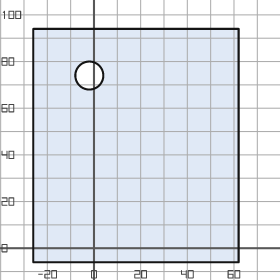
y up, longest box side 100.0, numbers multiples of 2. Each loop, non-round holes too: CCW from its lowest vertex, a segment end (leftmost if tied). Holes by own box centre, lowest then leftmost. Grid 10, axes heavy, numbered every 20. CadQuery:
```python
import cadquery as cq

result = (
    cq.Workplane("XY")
    .moveTo(-26.0, -6.0)
    .lineTo(62.0, -6.0)
    .lineTo(62.0, 94.0)
    .lineTo(-26.0, 94.0)
    .close()
    .moveTo(-2.0, 74.0)
    .circle(6.0)
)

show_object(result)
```